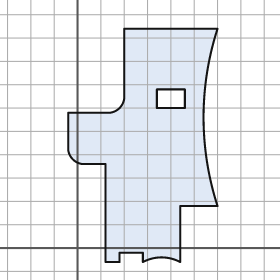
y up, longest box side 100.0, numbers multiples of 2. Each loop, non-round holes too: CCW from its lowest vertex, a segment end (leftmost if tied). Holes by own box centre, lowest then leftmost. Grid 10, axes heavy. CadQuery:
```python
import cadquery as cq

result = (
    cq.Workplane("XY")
    .moveTo(12.0, -6.0)
    .lineTo(18.0, -6.0)
    .lineTo(18.0, -2.0)
    .lineTo(28.0, -2.0)
    .lineTo(28.0, -6.0)
    .threePointArc((36.0, -4.0), (44.0, -6.0))
    .lineTo(44.0, 18.0)
    .lineTo(60.0, 18.0)
    .threePointArc((54.0, 56.0), (60.0, 94.0))
    .lineTo(20.0, 94.0)
    .lineTo(20.0, 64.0)
    .threePointArc((18.0, 60.0), (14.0, 58.0))
    .lineTo(-4.0, 58.0)
    .lineTo(-4.0, 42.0)
    .threePointArc((-2.0, 38.0), (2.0, 36.0))
    .lineTo(12.0, 36.0)
    .close()
    .moveTo(34.0, 60.0)
    .lineTo(46.0, 60.0)
    .lineTo(46.0, 68.0)
    .lineTo(34.0, 68.0)
    .close()
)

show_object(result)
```